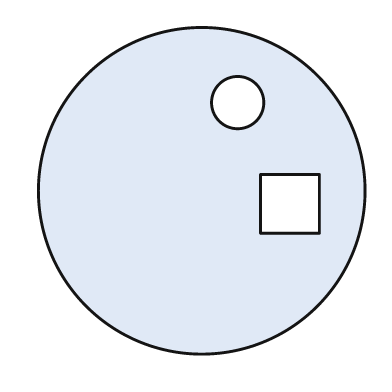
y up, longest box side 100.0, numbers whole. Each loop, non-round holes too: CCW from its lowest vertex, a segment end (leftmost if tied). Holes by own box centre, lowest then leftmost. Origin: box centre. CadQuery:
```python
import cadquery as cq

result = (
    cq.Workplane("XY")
    .moveTo(0.0, 0.0)
    .circle(50.0)
    .moveTo(18.0, -13.0)
    .lineTo(36.0, -13.0)
    .lineTo(36.0, 5.0)
    .lineTo(18.0, 5.0)
    .close()
    .moveTo(11.0, 27.0)
    .circle(8.0)
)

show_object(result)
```